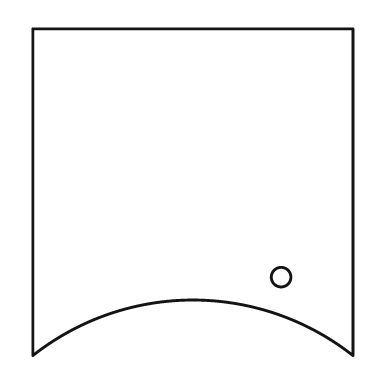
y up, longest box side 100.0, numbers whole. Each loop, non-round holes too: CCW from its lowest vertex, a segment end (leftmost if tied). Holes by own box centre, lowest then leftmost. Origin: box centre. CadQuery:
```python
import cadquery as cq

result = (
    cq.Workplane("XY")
    .moveTo(-49.0, -50.0)
    .threePointArc((0.0, -33.0), (49.0, -50.0))
    .lineTo(49.0, 50.0)
    .lineTo(-49.0, 50.0)
    .close()
    .moveTo(27.0, -26.0)
    .circle(3.0)
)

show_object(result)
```